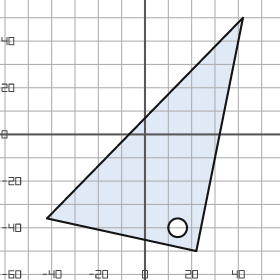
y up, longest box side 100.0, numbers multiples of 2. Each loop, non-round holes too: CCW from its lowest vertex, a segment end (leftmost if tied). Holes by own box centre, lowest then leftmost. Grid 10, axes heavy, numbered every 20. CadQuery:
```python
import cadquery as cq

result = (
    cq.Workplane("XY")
    .moveTo(22.0, -50.0)
    .lineTo(42.0, 50.0)
    .lineTo(-42.0, -36.0)
    .close()
    .moveTo(14.0, -40.0)
    .circle(4.0)
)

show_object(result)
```